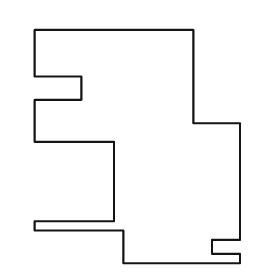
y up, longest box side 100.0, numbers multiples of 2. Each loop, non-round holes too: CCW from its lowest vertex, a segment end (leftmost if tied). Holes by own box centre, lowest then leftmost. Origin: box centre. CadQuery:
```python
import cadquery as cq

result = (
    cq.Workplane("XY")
    .moveTo(-6.0, -50.0)
    .lineTo(44.0, -50.0)
    .lineTo(44.0, -46.0)
    .lineTo(32.0, -46.0)
    .lineTo(32.0, -40.0)
    .lineTo(44.0, -40.0)
    .lineTo(44.0, 10.0)
    .lineTo(24.0, 10.0)
    .lineTo(24.0, 50.0)
    .lineTo(-44.0, 50.0)
    .lineTo(-44.0, 30.0)
    .lineTo(-24.0, 30.0)
    .lineTo(-24.0, 20.0)
    .lineTo(-44.0, 20.0)
    .lineTo(-44.0, 2.0)
    .lineTo(-10.0, 2.0)
    .lineTo(-10.0, -32.0)
    .lineTo(-44.0, -32.0)
    .lineTo(-44.0, -36.0)
    .lineTo(-6.0, -36.0)
    .close()
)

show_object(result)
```